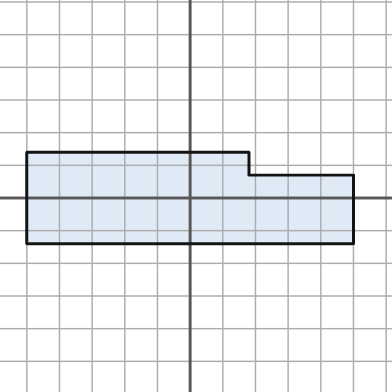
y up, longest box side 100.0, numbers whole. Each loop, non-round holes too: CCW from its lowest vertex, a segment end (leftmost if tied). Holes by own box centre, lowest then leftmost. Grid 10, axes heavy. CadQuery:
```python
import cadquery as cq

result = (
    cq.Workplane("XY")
    .moveTo(-50.0, -14.0)
    .lineTo(50.0, -14.0)
    .lineTo(50.0, 7.0)
    .lineTo(18.0, 7.0)
    .lineTo(18.0, 14.0)
    .lineTo(-50.0, 14.0)
    .close()
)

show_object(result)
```